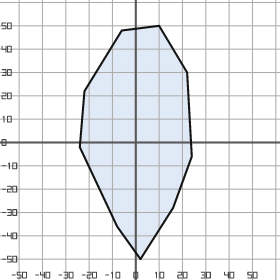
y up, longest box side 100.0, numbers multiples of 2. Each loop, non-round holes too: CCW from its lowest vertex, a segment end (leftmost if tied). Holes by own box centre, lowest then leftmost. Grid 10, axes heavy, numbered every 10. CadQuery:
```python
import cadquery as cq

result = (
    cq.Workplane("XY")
    .moveTo(2.0, -50.0)
    .lineTo(16.0, -28.0)
    .lineTo(24.0, -6.0)
    .lineTo(22.0, 30.0)
    .lineTo(10.0, 50.0)
    .lineTo(-6.0, 48.0)
    .lineTo(-22.0, 22.0)
    .lineTo(-24.0, -2.0)
    .lineTo(-8.0, -36.0)
    .close()
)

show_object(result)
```